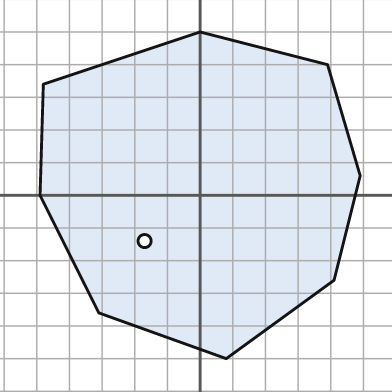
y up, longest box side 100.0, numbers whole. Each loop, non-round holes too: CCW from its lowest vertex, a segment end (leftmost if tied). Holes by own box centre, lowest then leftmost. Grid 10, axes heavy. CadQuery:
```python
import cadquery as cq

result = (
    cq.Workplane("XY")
    .moveTo(8.0, -50.0)
    .lineTo(41.0, -26.0)
    .lineTo(49.0, 6.0)
    .lineTo(39.0, 40.0)
    .lineTo(0.0, 50.0)
    .lineTo(-48.0, 34.0)
    .lineTo(-49.0, 0.0)
    .lineTo(-31.0, -36.0)
    .close()
    .moveTo(-17.0, -14.0)
    .circle(2.0)
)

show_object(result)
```